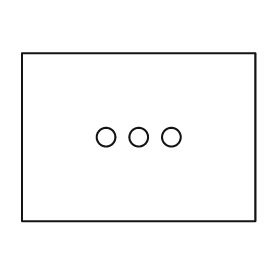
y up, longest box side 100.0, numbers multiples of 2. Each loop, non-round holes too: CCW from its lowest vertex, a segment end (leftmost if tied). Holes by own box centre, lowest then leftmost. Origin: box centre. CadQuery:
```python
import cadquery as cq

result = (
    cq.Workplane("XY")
    .moveTo(-50.0, -36.0)
    .lineTo(50.0, -36.0)
    .lineTo(50.0, 36.0)
    .lineTo(-50.0, 36.0)
    .close()
    .moveTo(-14.0, 0.0)
    .circle(4.0)
    .moveTo(0.0, 0.0)
    .circle(4.0)
    .moveTo(14.0, 0.0)
    .circle(4.0)
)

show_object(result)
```